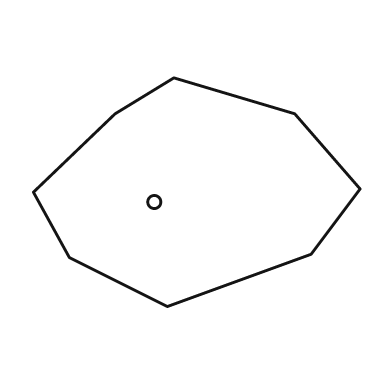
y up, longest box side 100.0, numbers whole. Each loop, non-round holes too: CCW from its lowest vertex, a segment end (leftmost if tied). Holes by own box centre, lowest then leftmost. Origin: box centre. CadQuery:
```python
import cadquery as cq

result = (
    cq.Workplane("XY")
    .moveTo(-9.0, -35.0)
    .lineTo(35.0, -19.0)
    .lineTo(50.0, 1.0)
    .lineTo(30.0, 24.0)
    .lineTo(-7.0, 35.0)
    .lineTo(-25.0, 24.0)
    .lineTo(-50.0, 0.0)
    .lineTo(-39.0, -20.0)
    .close()
    .moveTo(-13.0, -3.0)
    .circle(2.0)
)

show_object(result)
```